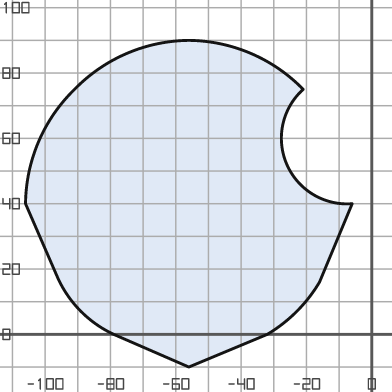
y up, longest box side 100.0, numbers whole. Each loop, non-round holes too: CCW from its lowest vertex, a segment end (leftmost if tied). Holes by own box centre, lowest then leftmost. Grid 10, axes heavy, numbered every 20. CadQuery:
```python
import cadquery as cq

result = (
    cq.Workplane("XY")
    .moveTo(-56.0, -10.0)
    .lineTo(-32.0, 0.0)
    .threePointArc((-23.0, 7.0), (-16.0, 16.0))
    .lineTo(-6.0, 40.0)
    .threePointArc((-26.0, 52.0), (-21.0, 75.0))
    .threePointArc((-37.0, 86.0), (-56.0, 90.0))
    .threePointArc((-75.0, 86.0), (-91.0, 75.0))
    .threePointArc((-102.0, 59.0), (-106.0, 40.0))
    .lineTo(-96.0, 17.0)
    .threePointArc((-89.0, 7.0), (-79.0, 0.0))
    .close()
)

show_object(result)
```